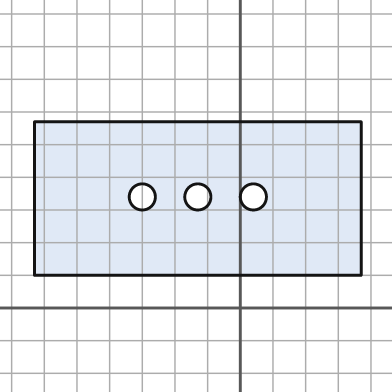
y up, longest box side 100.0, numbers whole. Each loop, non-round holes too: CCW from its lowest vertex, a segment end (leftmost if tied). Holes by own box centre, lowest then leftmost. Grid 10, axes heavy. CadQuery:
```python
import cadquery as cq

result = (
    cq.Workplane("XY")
    .moveTo(-63.0, 10.0)
    .lineTo(37.0, 10.0)
    .lineTo(37.0, 57.0)
    .lineTo(-63.0, 57.0)
    .close()
    .moveTo(-30.0, 34.0)
    .circle(4.0)
    .moveTo(-13.0, 34.0)
    .circle(4.0)
    .moveTo(4.0, 34.0)
    .circle(4.0)
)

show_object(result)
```